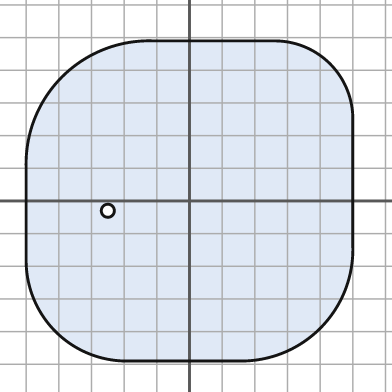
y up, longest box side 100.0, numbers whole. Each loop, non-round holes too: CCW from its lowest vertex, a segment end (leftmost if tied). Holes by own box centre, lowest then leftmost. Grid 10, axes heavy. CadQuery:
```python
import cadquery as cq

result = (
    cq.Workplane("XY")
    .moveTo(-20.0, -49.0)
    .lineTo(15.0, -49.0)
    .threePointArc((40.0, -39.0), (50.0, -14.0))
    .lineTo(50.0, 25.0)
    .threePointArc((43.0, 42.0), (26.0, 49.0))
    .lineTo(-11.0, 49.0)
    .threePointArc((-39.0, 38.0), (-50.0, 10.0))
    .lineTo(-50.0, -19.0)
    .threePointArc((-41.0, -40.0), (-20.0, -49.0))
    .close()
    .moveTo(-25.0, -3.0)
    .circle(2.0)
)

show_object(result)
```